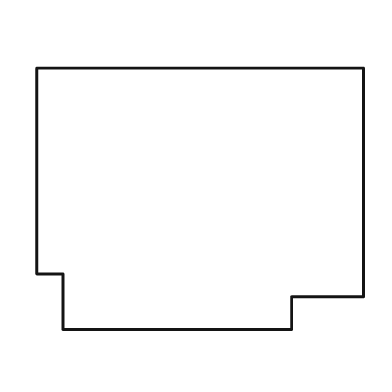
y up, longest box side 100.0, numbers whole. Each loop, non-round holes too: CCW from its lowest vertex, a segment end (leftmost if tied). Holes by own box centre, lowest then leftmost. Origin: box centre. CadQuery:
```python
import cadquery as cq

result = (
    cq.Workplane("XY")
    .moveTo(-42.0, -40.0)
    .lineTo(28.0, -40.0)
    .lineTo(28.0, -30.0)
    .lineTo(50.0, -30.0)
    .lineTo(50.0, 40.0)
    .lineTo(-50.0, 40.0)
    .lineTo(-50.0, -23.0)
    .lineTo(-42.0, -23.0)
    .close()
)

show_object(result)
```